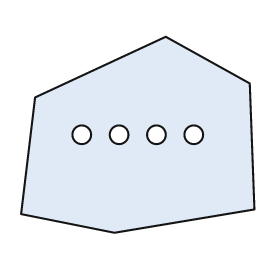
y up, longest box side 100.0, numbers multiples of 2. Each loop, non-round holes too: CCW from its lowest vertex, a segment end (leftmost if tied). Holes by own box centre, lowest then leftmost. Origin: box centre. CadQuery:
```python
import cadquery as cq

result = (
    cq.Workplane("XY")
    .moveTo(-10.0, -42.0)
    .lineTo(50.0, -32.0)
    .lineTo(48.0, 22.0)
    .lineTo(12.0, 42.0)
    .lineTo(-44.0, 16.0)
    .lineTo(-50.0, -34.0)
    .close()
    .moveTo(-24.0, 0.0)
    .circle(4.0)
    .moveTo(-8.0, 0.0)
    .circle(4.0)
    .moveTo(8.0, 0.0)
    .circle(4.0)
    .moveTo(24.0, 0.0)
    .circle(4.0)
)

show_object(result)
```